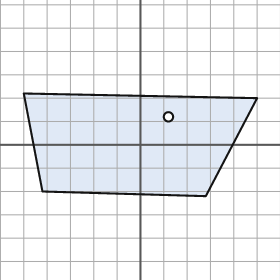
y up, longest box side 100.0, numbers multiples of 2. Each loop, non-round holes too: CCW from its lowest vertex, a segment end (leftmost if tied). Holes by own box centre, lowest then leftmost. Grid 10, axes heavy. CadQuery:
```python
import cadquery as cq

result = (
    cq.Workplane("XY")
    .moveTo(28.0, -22.0)
    .lineTo(50.0, 20.0)
    .lineTo(-50.0, 22.0)
    .lineTo(-42.0, -20.0)
    .close()
    .moveTo(12.0, 12.0)
    .circle(2.0)
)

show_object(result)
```